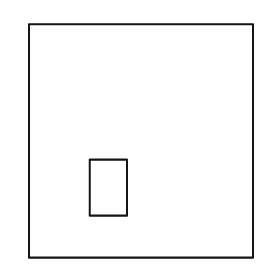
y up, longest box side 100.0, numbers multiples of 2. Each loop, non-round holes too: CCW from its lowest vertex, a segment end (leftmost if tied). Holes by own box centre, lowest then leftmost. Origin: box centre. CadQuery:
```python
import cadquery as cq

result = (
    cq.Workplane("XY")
    .moveTo(-48.0, -50.0)
    .lineTo(48.0, -50.0)
    .lineTo(48.0, 50.0)
    .lineTo(-48.0, 50.0)
    .close()
    .moveTo(-22.0, -32.0)
    .lineTo(-6.0, -32.0)
    .lineTo(-6.0, -8.0)
    .lineTo(-22.0, -8.0)
    .close()
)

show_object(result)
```